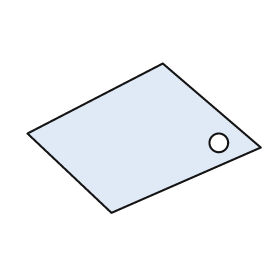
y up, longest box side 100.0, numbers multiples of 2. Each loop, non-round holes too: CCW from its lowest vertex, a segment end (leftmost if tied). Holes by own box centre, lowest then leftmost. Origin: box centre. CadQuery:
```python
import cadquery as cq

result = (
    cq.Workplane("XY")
    .moveTo(-14.0, -32.0)
    .lineTo(50.0, -4.0)
    .lineTo(8.0, 32.0)
    .lineTo(-50.0, 2.0)
    .close()
    .moveTo(32.0, -2.0)
    .circle(4.0)
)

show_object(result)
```